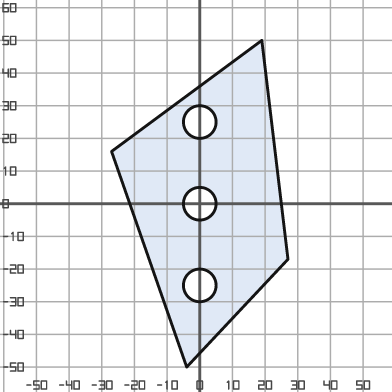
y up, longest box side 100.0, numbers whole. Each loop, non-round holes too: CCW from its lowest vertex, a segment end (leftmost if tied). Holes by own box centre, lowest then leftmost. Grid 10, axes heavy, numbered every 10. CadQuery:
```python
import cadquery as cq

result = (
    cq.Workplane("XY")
    .moveTo(-4.0, -50.0)
    .lineTo(27.0, -17.0)
    .lineTo(19.0, 50.0)
    .lineTo(-27.0, 16.0)
    .close()
    .moveTo(0.0, -25.0)
    .circle(5.0)
    .moveTo(0.0, 0.0)
    .circle(5.0)
    .moveTo(0.0, 25.0)
    .circle(5.0)
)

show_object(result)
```